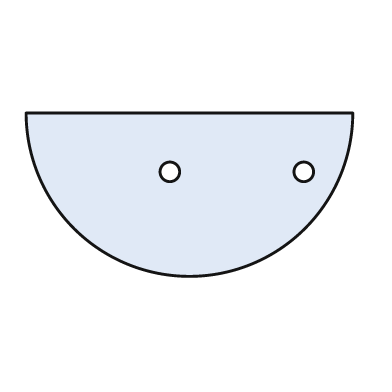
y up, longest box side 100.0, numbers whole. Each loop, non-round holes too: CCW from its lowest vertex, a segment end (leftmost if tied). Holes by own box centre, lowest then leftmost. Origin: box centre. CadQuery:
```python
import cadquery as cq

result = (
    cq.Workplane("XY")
    .moveTo(-50.0, 25.0)
    .threePointArc((0.0, -25.0), (50.0, 25.0))
    .close()
    .moveTo(-6.0, 7.0)
    .circle(3.0)
    .moveTo(35.0, 7.0)
    .circle(3.0)
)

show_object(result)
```